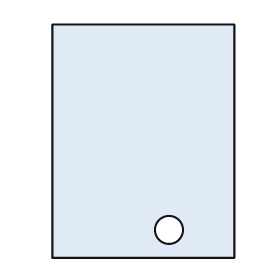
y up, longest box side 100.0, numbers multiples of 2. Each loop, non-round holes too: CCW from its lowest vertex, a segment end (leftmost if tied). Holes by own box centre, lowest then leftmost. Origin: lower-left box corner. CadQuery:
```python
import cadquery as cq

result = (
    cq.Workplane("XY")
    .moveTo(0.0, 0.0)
    .lineTo(78.0, 0.0)
    .lineTo(78.0, 100.0)
    .lineTo(0.0, 100.0)
    .close()
    .moveTo(50.0, 12.0)
    .circle(6.0)
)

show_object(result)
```